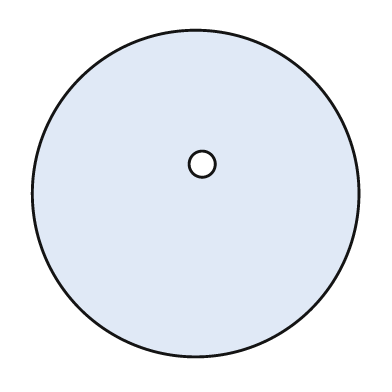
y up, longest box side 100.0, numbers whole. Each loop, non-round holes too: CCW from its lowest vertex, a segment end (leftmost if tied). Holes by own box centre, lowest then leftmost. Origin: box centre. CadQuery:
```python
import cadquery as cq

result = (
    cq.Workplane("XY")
    .moveTo(0.0, 0.0)
    .circle(50.0)
    .moveTo(2.0, 9.0)
    .circle(4.0)
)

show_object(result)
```